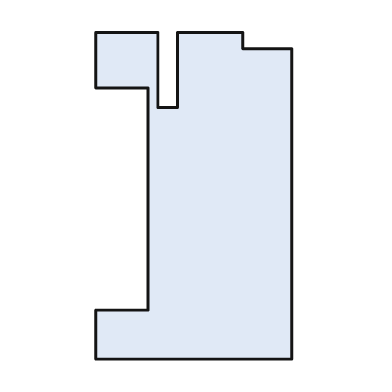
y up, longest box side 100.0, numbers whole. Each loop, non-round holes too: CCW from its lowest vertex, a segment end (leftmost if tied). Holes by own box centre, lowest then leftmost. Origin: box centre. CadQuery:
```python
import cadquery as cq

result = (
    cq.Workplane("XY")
    .moveTo(-30.0, -50.0)
    .lineTo(30.0, -50.0)
    .lineTo(30.0, 45.0)
    .lineTo(15.0, 45.0)
    .lineTo(15.0, 50.0)
    .lineTo(-5.0, 50.0)
    .lineTo(-5.0, 27.0)
    .lineTo(-11.0, 27.0)
    .lineTo(-11.0, 50.0)
    .lineTo(-30.0, 50.0)
    .lineTo(-30.0, 33.0)
    .lineTo(-14.0, 33.0)
    .lineTo(-14.0, -35.0)
    .lineTo(-30.0, -35.0)
    .close()
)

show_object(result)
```